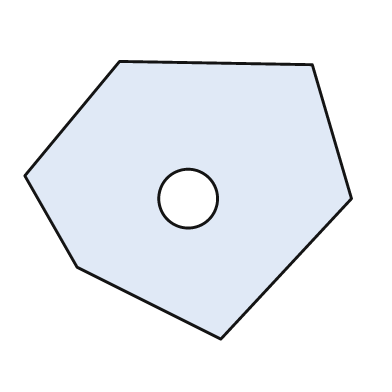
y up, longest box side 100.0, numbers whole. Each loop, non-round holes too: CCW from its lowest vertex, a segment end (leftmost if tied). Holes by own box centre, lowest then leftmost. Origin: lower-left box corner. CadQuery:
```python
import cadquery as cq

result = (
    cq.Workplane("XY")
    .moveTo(60.0, 0.0)
    .lineTo(100.0, 43.0)
    .lineTo(88.0, 84.0)
    .lineTo(29.0, 85.0)
    .lineTo(0.0, 50.0)
    .lineTo(16.0, 22.0)
    .close()
    .moveTo(50.0, 43.0)
    .circle(9.0)
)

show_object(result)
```